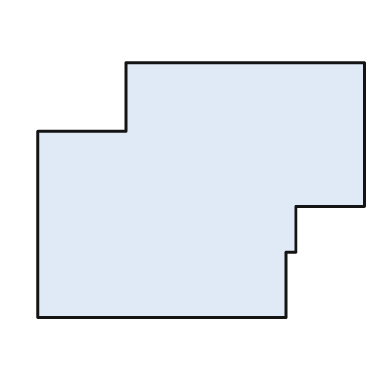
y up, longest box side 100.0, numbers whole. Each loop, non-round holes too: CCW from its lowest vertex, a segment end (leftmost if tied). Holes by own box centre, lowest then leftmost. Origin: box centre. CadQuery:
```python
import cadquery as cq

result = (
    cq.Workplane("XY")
    .moveTo(-50.0, -39.0)
    .lineTo(26.0, -39.0)
    .lineTo(26.0, -19.0)
    .lineTo(29.0, -19.0)
    .lineTo(29.0, -5.0)
    .lineTo(50.0, -5.0)
    .lineTo(50.0, 39.0)
    .lineTo(-23.0, 39.0)
    .lineTo(-23.0, 18.0)
    .lineTo(-50.0, 18.0)
    .close()
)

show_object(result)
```